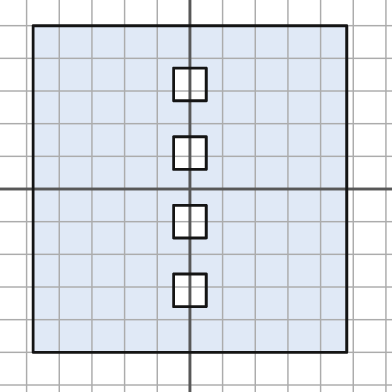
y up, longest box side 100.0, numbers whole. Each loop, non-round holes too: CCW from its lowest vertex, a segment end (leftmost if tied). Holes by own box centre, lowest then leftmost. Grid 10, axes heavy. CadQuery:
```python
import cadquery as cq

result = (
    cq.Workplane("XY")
    .moveTo(-48.0, -50.0)
    .lineTo(48.0, -50.0)
    .lineTo(48.0, 50.0)
    .lineTo(-48.0, 50.0)
    .close()
    .moveTo(-5.0, -36.0)
    .lineTo(5.0, -36.0)
    .lineTo(5.0, -26.0)
    .lineTo(-5.0, -26.0)
    .close()
    .moveTo(-5.0, -15.0)
    .lineTo(5.0, -15.0)
    .lineTo(5.0, -5.0)
    .lineTo(-5.0, -5.0)
    .close()
    .moveTo(-5.0, 6.0)
    .lineTo(5.0, 6.0)
    .lineTo(5.0, 16.0)
    .lineTo(-5.0, 16.0)
    .close()
    .moveTo(-5.0, 27.0)
    .lineTo(5.0, 27.0)
    .lineTo(5.0, 37.0)
    .lineTo(-5.0, 37.0)
    .close()
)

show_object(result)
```